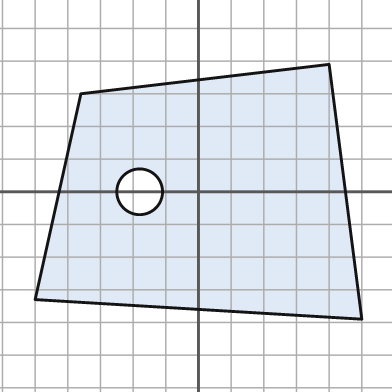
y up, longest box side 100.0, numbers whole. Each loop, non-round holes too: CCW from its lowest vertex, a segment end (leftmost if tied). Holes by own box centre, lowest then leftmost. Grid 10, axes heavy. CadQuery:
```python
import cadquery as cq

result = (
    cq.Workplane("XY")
    .moveTo(50.0, -39.0)
    .lineTo(40.0, 39.0)
    .lineTo(-36.0, 30.0)
    .lineTo(-50.0, -33.0)
    .close()
    .moveTo(-18.0, 0.0)
    .circle(7.0)
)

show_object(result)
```